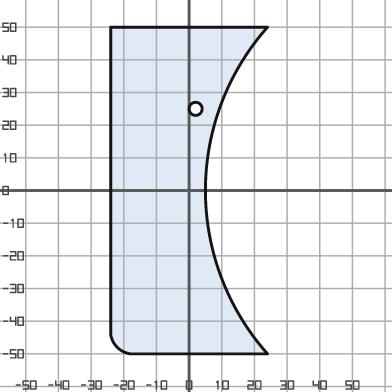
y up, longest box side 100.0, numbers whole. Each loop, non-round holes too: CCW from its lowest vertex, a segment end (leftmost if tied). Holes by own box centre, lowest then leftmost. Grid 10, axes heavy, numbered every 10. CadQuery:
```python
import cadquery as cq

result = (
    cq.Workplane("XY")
    .moveTo(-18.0, -50.0)
    .lineTo(24.0, -50.0)
    .threePointArc((5.0, 0.0), (24.0, 50.0))
    .lineTo(-24.0, 50.0)
    .lineTo(-24.0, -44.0)
    .threePointArc((-22.0, -48.0), (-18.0, -50.0))
    .close()
    .moveTo(2.0, 25.0)
    .circle(2.0)
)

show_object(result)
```